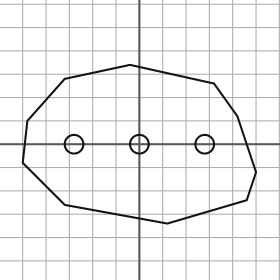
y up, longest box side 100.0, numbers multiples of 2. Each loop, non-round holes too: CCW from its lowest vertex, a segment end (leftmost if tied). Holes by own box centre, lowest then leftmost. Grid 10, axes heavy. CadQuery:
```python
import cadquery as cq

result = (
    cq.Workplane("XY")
    .moveTo(12.0, -34.0)
    .lineTo(46.0, -24.0)
    .lineTo(50.0, -12.0)
    .lineTo(42.0, 12.0)
    .lineTo(32.0, 26.0)
    .lineTo(-4.0, 34.0)
    .lineTo(-32.0, 28.0)
    .lineTo(-48.0, 10.0)
    .lineTo(-50.0, -8.0)
    .lineTo(-32.0, -26.0)
    .close()
    .moveTo(-28.0, 0.0)
    .circle(4.0)
    .moveTo(0.0, 0.0)
    .circle(4.0)
    .moveTo(28.0, 0.0)
    .circle(4.0)
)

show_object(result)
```